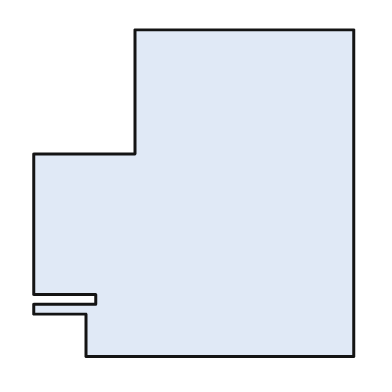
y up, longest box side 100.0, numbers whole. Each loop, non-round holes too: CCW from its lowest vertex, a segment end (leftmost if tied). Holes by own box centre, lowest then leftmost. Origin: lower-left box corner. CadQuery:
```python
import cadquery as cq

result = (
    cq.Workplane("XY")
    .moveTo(16.0, 0.0)
    .lineTo(98.0, 0.0)
    .lineTo(98.0, 100.0)
    .lineTo(31.0, 100.0)
    .lineTo(31.0, 62.0)
    .lineTo(0.0, 62.0)
    .lineTo(0.0, 19.0)
    .lineTo(19.0, 19.0)
    .lineTo(19.0, 16.0)
    .lineTo(0.0, 16.0)
    .lineTo(0.0, 13.0)
    .lineTo(16.0, 13.0)
    .close()
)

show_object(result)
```